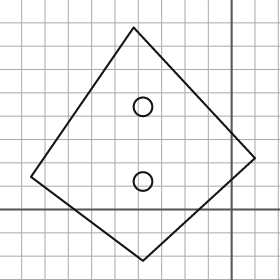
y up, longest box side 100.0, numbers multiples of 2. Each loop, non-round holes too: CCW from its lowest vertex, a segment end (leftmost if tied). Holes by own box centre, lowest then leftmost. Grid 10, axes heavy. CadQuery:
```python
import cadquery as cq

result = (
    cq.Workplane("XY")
    .moveTo(-38.0, -22.0)
    .lineTo(10.0, 22.0)
    .lineTo(-42.0, 78.0)
    .lineTo(-86.0, 14.0)
    .close()
    .moveTo(-38.0, 12.0)
    .circle(4.0)
    .moveTo(-38.0, 44.0)
    .circle(4.0)
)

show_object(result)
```